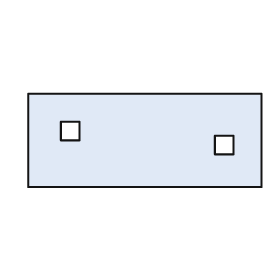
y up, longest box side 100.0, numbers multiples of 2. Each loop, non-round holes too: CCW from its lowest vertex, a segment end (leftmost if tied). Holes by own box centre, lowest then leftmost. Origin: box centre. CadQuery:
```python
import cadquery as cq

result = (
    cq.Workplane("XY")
    .moveTo(-50.0, -20.0)
    .lineTo(50.0, -20.0)
    .lineTo(50.0, 20.0)
    .lineTo(-50.0, 20.0)
    .close()
    .moveTo(30.0, -6.0)
    .lineTo(38.0, -6.0)
    .lineTo(38.0, 2.0)
    .lineTo(30.0, 2.0)
    .close()
    .moveTo(-36.0, 0.0)
    .lineTo(-28.0, 0.0)
    .lineTo(-28.0, 8.0)
    .lineTo(-36.0, 8.0)
    .close()
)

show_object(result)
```